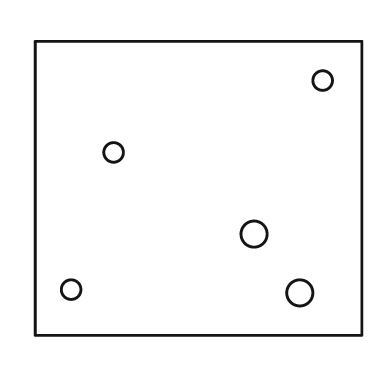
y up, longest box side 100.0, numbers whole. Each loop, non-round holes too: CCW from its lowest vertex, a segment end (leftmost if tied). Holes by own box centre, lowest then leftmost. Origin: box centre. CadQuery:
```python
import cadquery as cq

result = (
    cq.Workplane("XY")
    .moveTo(-50.0, -45.0)
    .lineTo(50.0, -45.0)
    .lineTo(50.0, 45.0)
    .lineTo(-50.0, 45.0)
    .close()
    .moveTo(31.0, -32.0)
    .circle(4.0)
    .moveTo(-39.0, -31.0)
    .circle(3.0)
    .moveTo(17.0, -14.0)
    .circle(4.0)
    .moveTo(-26.0, 11.0)
    .circle(3.0)
    .moveTo(38.0, 33.0)
    .circle(3.0)
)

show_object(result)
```